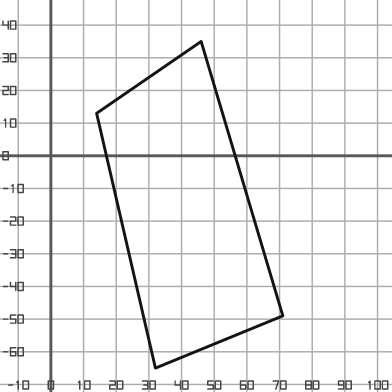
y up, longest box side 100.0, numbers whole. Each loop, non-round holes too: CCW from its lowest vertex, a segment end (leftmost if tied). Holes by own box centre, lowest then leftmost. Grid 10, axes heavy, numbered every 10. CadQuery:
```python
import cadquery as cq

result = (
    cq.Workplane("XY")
    .moveTo(32.0, -65.0)
    .lineTo(71.0, -49.0)
    .lineTo(46.0, 35.0)
    .lineTo(14.0, 13.0)
    .close()
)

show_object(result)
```